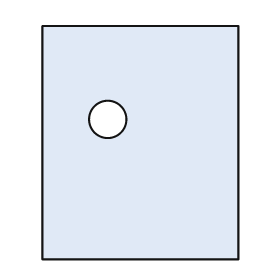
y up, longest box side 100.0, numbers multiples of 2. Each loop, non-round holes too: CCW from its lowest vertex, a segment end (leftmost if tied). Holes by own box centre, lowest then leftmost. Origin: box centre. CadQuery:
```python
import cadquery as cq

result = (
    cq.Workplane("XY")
    .moveTo(-42.0, -50.0)
    .lineTo(42.0, -50.0)
    .lineTo(42.0, 50.0)
    .lineTo(-42.0, 50.0)
    .close()
    .moveTo(-14.0, 10.0)
    .circle(8.0)
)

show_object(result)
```